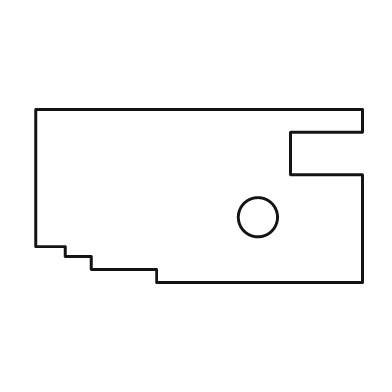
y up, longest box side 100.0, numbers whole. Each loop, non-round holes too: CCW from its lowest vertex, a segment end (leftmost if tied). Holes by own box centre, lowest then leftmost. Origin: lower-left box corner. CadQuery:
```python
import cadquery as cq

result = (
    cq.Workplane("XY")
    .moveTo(37.0, 0.0)
    .lineTo(100.0, 0.0)
    .lineTo(100.0, 33.0)
    .lineTo(78.0, 33.0)
    .lineTo(78.0, 46.0)
    .lineTo(100.0, 46.0)
    .lineTo(100.0, 53.0)
    .lineTo(0.0, 53.0)
    .lineTo(0.0, 11.0)
    .lineTo(9.0, 11.0)
    .lineTo(9.0, 8.0)
    .lineTo(17.0, 8.0)
    .lineTo(17.0, 4.0)
    .lineTo(37.0, 4.0)
    .close()
    .moveTo(68.0, 20.0)
    .circle(6.0)
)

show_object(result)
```